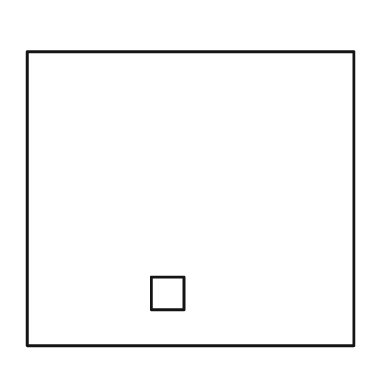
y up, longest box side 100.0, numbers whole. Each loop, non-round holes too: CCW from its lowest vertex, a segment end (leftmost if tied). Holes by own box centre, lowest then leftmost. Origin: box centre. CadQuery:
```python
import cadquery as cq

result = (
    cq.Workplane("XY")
    .moveTo(-50.0, -45.0)
    .lineTo(50.0, -45.0)
    .lineTo(50.0, 45.0)
    .lineTo(-50.0, 45.0)
    .close()
    .moveTo(-12.0, -34.0)
    .lineTo(-2.0, -34.0)
    .lineTo(-2.0, -24.0)
    .lineTo(-12.0, -24.0)
    .close()
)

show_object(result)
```